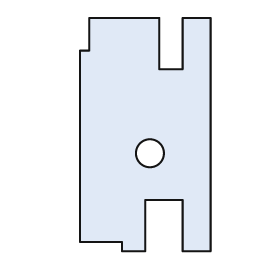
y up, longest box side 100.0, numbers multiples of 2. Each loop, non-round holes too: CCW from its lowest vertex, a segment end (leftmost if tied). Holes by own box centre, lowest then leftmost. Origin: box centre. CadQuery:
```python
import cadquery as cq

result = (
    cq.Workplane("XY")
    .moveTo(-10.0, -50.0)
    .lineTo(0.0, -50.0)
    .lineTo(0.0, -28.0)
    .lineTo(16.0, -28.0)
    .lineTo(16.0, -50.0)
    .lineTo(28.0, -50.0)
    .lineTo(28.0, 50.0)
    .lineTo(16.0, 50.0)
    .lineTo(16.0, 28.0)
    .lineTo(6.0, 28.0)
    .lineTo(6.0, 50.0)
    .lineTo(-24.0, 50.0)
    .lineTo(-24.0, 36.0)
    .lineTo(-28.0, 36.0)
    .lineTo(-28.0, -46.0)
    .lineTo(-10.0, -46.0)
    .close()
    .moveTo(2.0, -8.0)
    .circle(6.0)
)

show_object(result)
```